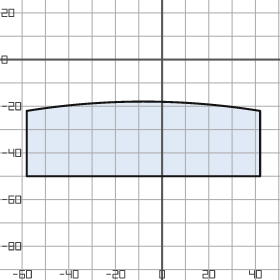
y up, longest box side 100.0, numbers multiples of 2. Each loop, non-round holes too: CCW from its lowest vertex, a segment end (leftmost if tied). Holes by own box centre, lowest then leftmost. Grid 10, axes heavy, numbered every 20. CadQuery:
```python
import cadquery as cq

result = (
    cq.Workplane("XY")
    .moveTo(-58.0, -50.0)
    .lineTo(42.0, -50.0)
    .lineTo(42.0, -22.0)
    .threePointArc((-8.0, -18.0), (-58.0, -22.0))
    .close()
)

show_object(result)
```